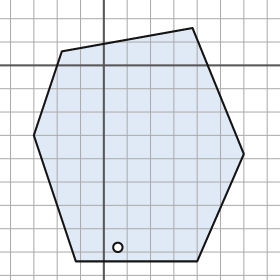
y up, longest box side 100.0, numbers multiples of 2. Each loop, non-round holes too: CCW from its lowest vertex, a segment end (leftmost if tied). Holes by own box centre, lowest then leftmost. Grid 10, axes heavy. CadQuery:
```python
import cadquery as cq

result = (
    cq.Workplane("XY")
    .moveTo(-12.0, -84.0)
    .lineTo(40.0, -84.0)
    .lineTo(60.0, -38.0)
    .lineTo(38.0, 16.0)
    .lineTo(-18.0, 6.0)
    .lineTo(-30.0, -30.0)
    .close()
    .moveTo(6.0, -78.0)
    .circle(2.0)
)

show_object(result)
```